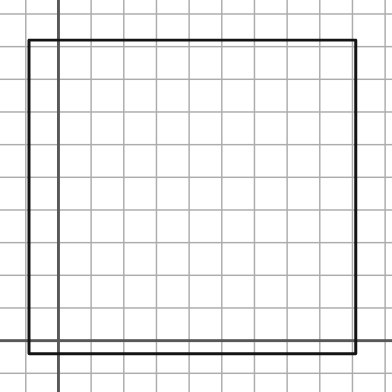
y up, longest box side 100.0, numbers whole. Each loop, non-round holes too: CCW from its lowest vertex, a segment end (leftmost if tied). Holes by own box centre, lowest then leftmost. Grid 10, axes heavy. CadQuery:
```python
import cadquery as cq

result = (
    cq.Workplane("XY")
    .moveTo(-9.0, -4.0)
    .lineTo(91.0, -4.0)
    .lineTo(91.0, 92.0)
    .lineTo(-9.0, 92.0)
    .close()
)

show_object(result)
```